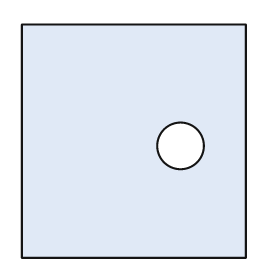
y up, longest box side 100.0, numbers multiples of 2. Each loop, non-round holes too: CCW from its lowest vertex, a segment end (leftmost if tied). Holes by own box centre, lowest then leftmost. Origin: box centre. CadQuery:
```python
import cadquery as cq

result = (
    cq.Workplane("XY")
    .moveTo(-48.0, -50.0)
    .lineTo(48.0, -50.0)
    .lineTo(48.0, 50.0)
    .lineTo(-48.0, 50.0)
    .close()
    .moveTo(20.0, -2.0)
    .circle(10.0)
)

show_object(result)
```